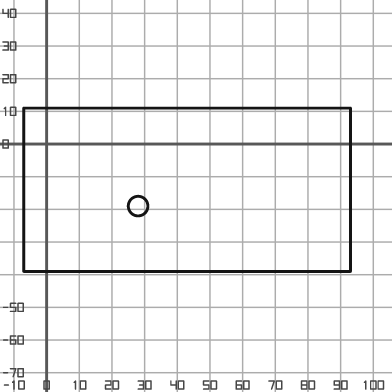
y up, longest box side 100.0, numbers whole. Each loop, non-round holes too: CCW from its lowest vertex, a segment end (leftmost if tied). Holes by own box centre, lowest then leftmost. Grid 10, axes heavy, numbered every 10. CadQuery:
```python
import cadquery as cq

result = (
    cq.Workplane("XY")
    .moveTo(-7.0, -39.0)
    .lineTo(93.0, -39.0)
    .lineTo(93.0, 11.0)
    .lineTo(-7.0, 11.0)
    .close()
    .moveTo(28.0, -19.0)
    .circle(3.0)
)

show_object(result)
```